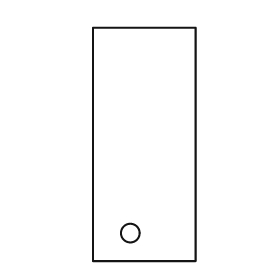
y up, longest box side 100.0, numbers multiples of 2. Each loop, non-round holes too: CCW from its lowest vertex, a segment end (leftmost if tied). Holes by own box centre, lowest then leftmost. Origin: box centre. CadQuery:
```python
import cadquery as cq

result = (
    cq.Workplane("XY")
    .moveTo(-22.0, -50.0)
    .lineTo(22.0, -50.0)
    .lineTo(22.0, 50.0)
    .lineTo(-22.0, 50.0)
    .close()
    .moveTo(-6.0, -38.0)
    .circle(4.0)
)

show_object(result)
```